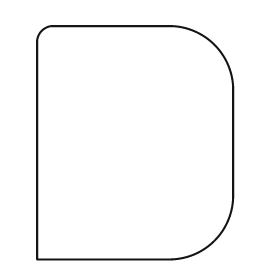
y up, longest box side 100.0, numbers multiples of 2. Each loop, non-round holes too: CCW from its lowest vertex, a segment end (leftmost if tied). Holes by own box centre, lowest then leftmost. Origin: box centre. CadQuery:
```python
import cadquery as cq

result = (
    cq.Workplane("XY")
    .moveTo(-42.0, -50.0)
    .lineTo(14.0, -50.0)
    .threePointArc((34.0, -42.0), (42.0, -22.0))
    .lineTo(42.0, 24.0)
    .threePointArc((34.0, 42.0), (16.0, 50.0))
    .lineTo(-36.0, 50.0)
    .threePointArc((-40.0, 48.0), (-42.0, 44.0))
    .close()
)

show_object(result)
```